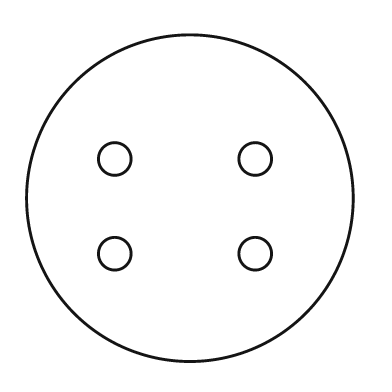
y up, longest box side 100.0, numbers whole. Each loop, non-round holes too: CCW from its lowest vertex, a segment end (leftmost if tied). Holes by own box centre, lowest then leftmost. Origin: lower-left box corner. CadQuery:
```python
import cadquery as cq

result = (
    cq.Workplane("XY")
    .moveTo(50.0, 50.0)
    .circle(50.0)
    .moveTo(27.0, 33.0)
    .circle(5.0)
    .moveTo(70.0, 33.0)
    .circle(5.0)
    .moveTo(27.0, 62.0)
    .circle(5.0)
    .moveTo(70.0, 62.0)
    .circle(5.0)
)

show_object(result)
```